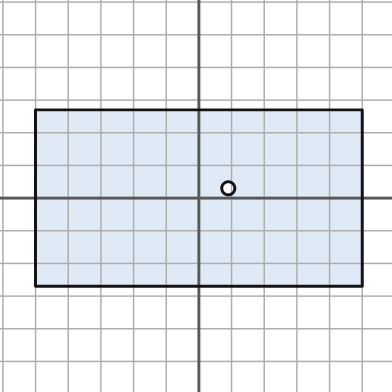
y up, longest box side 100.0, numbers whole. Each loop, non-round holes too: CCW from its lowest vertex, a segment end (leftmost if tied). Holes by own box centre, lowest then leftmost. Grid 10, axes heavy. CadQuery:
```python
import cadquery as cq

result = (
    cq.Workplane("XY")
    .moveTo(-50.0, -27.0)
    .lineTo(50.0, -27.0)
    .lineTo(50.0, 27.0)
    .lineTo(-50.0, 27.0)
    .close()
    .moveTo(9.0, 3.0)
    .circle(2.0)
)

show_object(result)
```